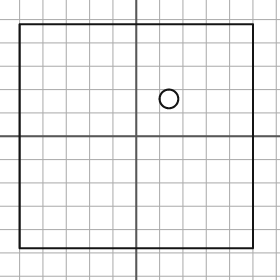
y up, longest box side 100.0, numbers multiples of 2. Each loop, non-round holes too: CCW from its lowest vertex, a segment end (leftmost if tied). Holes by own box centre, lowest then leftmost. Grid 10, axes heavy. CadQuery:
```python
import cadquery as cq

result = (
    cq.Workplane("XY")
    .moveTo(-50.0, -48.0)
    .lineTo(50.0, -48.0)
    .lineTo(50.0, 48.0)
    .lineTo(-50.0, 48.0)
    .close()
    .moveTo(14.0, 16.0)
    .circle(4.0)
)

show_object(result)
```